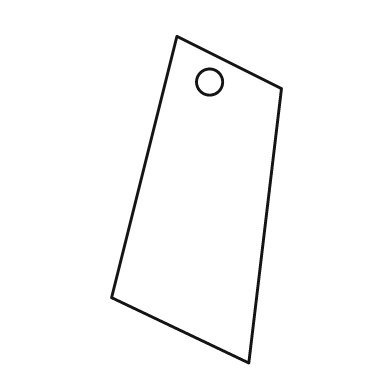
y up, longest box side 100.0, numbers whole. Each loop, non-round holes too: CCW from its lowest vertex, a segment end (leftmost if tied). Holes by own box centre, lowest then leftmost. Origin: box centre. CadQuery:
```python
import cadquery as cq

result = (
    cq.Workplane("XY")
    .moveTo(16.0, -50.0)
    .lineTo(26.0, 34.0)
    .lineTo(-6.0, 50.0)
    .lineTo(-26.0, -30.0)
    .close()
    .moveTo(4.0, 36.0)
    .circle(4.0)
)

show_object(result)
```